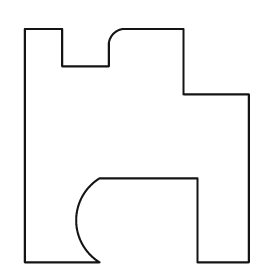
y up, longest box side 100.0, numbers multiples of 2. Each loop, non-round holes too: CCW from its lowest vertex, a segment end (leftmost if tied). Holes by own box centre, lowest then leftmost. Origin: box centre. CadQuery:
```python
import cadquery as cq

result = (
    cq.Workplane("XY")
    .moveTo(-48.0, -50.0)
    .lineTo(-16.0, -50.0)
    .threePointArc((-26.0, -32.0), (-16.0, -14.0))
    .lineTo(26.0, -14.0)
    .lineTo(26.0, -50.0)
    .lineTo(48.0, -50.0)
    .lineTo(48.0, 22.0)
    .lineTo(20.0, 22.0)
    .lineTo(20.0, 50.0)
    .lineTo(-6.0, 50.0)
    .threePointArc((-10.0, 48.0), (-12.0, 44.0))
    .lineTo(-12.0, 34.0)
    .lineTo(-32.0, 34.0)
    .lineTo(-32.0, 50.0)
    .lineTo(-48.0, 50.0)
    .close()
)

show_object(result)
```